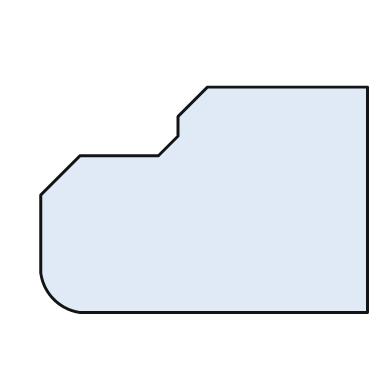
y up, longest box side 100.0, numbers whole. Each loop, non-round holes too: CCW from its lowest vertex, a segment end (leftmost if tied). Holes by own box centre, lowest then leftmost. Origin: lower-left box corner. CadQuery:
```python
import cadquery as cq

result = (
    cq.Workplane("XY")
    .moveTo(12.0, 0.0)
    .lineTo(100.0, 0.0)
    .lineTo(100.0, 69.0)
    .lineTo(51.0, 69.0)
    .lineTo(42.0, 60.0)
    .lineTo(42.0, 54.0)
    .lineTo(36.0, 48.0)
    .lineTo(12.0, 48.0)
    .lineTo(0.0, 36.0)
    .lineTo(0.0, 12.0)
    .threePointArc((4.0, 4.0), (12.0, 0.0))
    .close()
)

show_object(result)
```